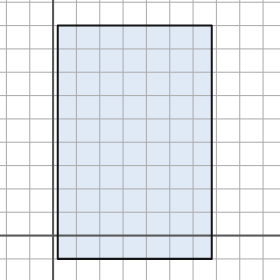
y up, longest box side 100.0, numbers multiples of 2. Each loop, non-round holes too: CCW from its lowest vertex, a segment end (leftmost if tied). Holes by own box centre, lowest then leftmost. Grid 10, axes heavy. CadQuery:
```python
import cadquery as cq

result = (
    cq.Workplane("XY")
    .moveTo(2.0, -10.0)
    .lineTo(68.0, -10.0)
    .lineTo(68.0, 90.0)
    .lineTo(2.0, 90.0)
    .close()
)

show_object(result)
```